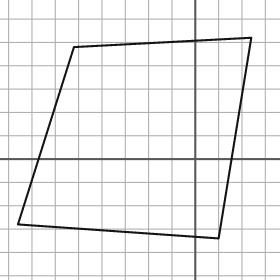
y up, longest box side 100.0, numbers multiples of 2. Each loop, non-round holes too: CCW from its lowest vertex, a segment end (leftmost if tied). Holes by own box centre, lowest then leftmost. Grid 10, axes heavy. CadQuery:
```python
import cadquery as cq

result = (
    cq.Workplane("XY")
    .moveTo(10.0, -34.0)
    .lineTo(24.0, 52.0)
    .lineTo(-52.0, 48.0)
    .lineTo(-76.0, -28.0)
    .close()
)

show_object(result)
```